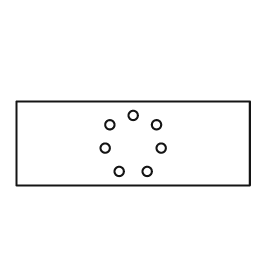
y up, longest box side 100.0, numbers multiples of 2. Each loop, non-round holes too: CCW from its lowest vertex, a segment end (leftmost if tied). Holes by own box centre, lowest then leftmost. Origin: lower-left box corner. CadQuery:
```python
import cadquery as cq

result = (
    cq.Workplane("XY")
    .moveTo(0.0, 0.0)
    .lineTo(100.0, 0.0)
    .lineTo(100.0, 36.0)
    .lineTo(0.0, 36.0)
    .close()
    .moveTo(44.0, 6.0)
    .circle(2.0)
    .moveTo(56.0, 6.0)
    .circle(2.0)
    .moveTo(38.0, 16.0)
    .circle(2.0)
    .moveTo(62.0, 16.0)
    .circle(2.0)
    .moveTo(40.0, 26.0)
    .circle(2.0)
    .moveTo(60.0, 26.0)
    .circle(2.0)
    .moveTo(50.0, 30.0)
    .circle(2.0)
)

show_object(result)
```